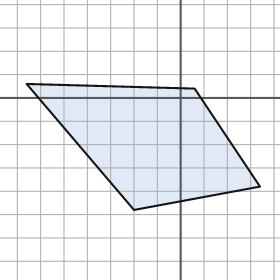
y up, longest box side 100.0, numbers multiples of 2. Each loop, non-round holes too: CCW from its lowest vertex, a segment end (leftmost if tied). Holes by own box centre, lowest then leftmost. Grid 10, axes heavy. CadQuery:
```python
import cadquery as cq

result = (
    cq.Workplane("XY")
    .moveTo(-20.0, -48.0)
    .lineTo(34.0, -38.0)
    .lineTo(6.0, 4.0)
    .lineTo(-66.0, 6.0)
    .close()
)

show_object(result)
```